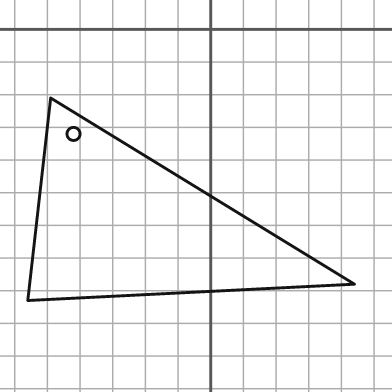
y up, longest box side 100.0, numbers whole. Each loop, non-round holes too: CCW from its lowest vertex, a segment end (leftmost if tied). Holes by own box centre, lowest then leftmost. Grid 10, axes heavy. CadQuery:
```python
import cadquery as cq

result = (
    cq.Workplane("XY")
    .moveTo(-56.0, -83.0)
    .lineTo(44.0, -78.0)
    .lineTo(-49.0, -21.0)
    .close()
    .moveTo(-42.0, -32.0)
    .circle(2.0)
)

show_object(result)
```